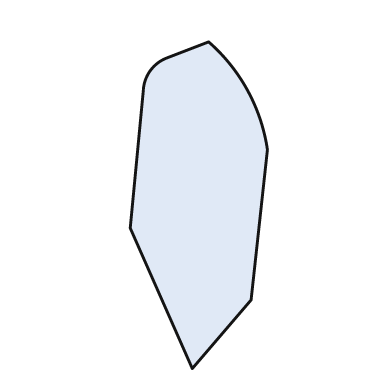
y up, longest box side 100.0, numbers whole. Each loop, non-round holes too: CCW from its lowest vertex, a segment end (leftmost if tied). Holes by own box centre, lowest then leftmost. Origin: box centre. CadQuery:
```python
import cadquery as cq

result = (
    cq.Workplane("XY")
    .moveTo(-2.0, -50.0)
    .lineTo(16.0, -29.0)
    .lineTo(21.0, 17.0)
    .threePointArc((15.0, 35.0), (3.0, 50.0))
    .lineTo(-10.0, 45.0)
    .threePointArc((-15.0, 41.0), (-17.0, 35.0))
    .lineTo(-21.0, -7.0)
    .close()
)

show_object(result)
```